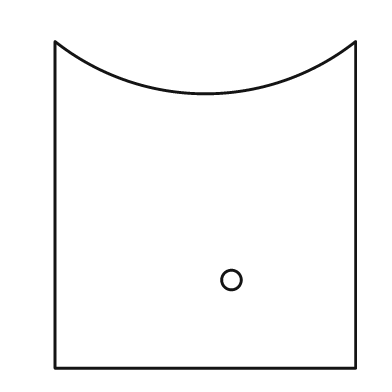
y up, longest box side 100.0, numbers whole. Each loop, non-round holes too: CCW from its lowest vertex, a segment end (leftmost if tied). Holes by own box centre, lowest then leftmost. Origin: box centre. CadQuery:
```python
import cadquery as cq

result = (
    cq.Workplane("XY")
    .moveTo(-46.0, -50.0)
    .lineTo(46.0, -50.0)
    .lineTo(46.0, 50.0)
    .threePointArc((0.0, 34.0), (-46.0, 50.0))
    .close()
    .moveTo(8.0, -23.0)
    .circle(3.0)
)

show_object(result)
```